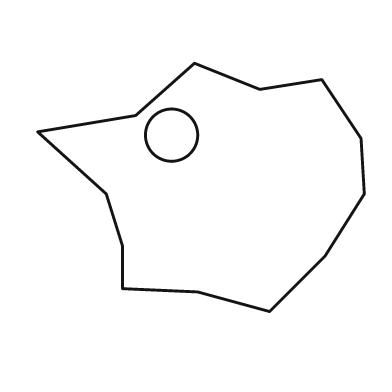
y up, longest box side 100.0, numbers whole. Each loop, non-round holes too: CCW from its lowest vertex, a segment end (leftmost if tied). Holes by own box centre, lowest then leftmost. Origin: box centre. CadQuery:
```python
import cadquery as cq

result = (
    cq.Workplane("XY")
    .moveTo(21.0, -38.0)
    .lineTo(38.0, -21.0)
    .lineTo(50.0, -2.0)
    .lineTo(49.0, 15.0)
    .lineTo(37.0, 33.0)
    .lineTo(18.0, 30.0)
    .lineTo(-2.0, 38.0)
    .lineTo(-20.0, 22.0)
    .lineTo(-50.0, 17.0)
    .lineTo(-29.0, -2.0)
    .lineTo(-24.0, -18.0)
    .lineTo(-24.0, -31.0)
    .lineTo(-1.0, -32.0)
    .close()
    .moveTo(-9.0, 16.0)
    .circle(8.0)
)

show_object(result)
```